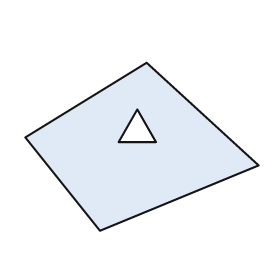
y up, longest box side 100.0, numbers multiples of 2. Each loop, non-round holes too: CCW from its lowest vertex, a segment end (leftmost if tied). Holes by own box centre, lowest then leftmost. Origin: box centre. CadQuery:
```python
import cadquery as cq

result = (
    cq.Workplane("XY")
    .moveTo(-18.0, -36.0)
    .lineTo(50.0, -8.0)
    .lineTo(2.0, 36.0)
    .lineTo(-50.0, 4.0)
    .close()
    .moveTo(-10.0, 2.0)
    .lineTo(6.0, 2.0)
    .lineTo(-2.0, 16.0)
    .close()
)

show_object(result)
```